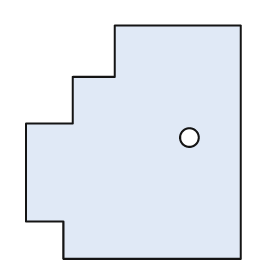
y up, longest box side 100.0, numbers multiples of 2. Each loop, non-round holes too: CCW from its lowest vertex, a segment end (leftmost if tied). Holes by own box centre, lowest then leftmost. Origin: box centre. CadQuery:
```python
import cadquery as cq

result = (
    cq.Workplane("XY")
    .moveTo(-30.0, -50.0)
    .lineTo(46.0, -50.0)
    .lineTo(46.0, 50.0)
    .lineTo(-8.0, 50.0)
    .lineTo(-8.0, 28.0)
    .lineTo(-26.0, 28.0)
    .lineTo(-26.0, 8.0)
    .lineTo(-46.0, 8.0)
    .lineTo(-46.0, -34.0)
    .lineTo(-30.0, -34.0)
    .close()
    .moveTo(24.0, 2.0)
    .circle(4.0)
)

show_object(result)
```